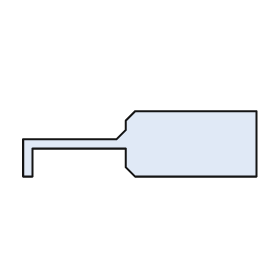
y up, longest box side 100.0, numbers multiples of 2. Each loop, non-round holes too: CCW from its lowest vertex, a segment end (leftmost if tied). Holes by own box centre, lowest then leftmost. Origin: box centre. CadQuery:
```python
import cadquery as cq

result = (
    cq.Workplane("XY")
    .moveTo(-50.0, -14.0)
    .lineTo(-46.0, -14.0)
    .lineTo(-46.0, -2.0)
    .lineTo(-6.0, -2.0)
    .lineTo(-6.0, -10.0)
    .lineTo(-2.0, -14.0)
    .lineTo(50.0, -14.0)
    .lineTo(50.0, 14.0)
    .lineTo(-2.0, 14.0)
    .lineTo(-6.0, 10.0)
    .lineTo(-6.0, 6.0)
    .lineTo(-10.0, 2.0)
    .lineTo(-50.0, 2.0)
    .close()
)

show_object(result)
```